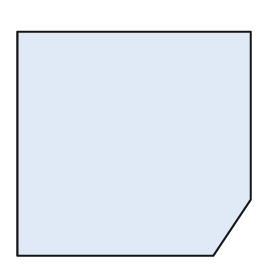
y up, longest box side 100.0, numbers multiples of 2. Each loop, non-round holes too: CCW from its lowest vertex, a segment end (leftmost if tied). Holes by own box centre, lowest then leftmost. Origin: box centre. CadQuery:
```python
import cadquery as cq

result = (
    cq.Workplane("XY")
    .moveTo(-50.0, -48.0)
    .lineTo(34.0, -48.0)
    .lineTo(50.0, -24.0)
    .lineTo(50.0, 48.0)
    .lineTo(-50.0, 48.0)
    .close()
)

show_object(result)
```